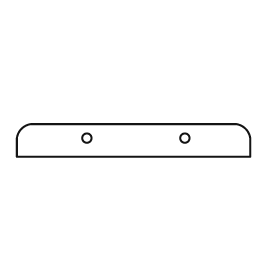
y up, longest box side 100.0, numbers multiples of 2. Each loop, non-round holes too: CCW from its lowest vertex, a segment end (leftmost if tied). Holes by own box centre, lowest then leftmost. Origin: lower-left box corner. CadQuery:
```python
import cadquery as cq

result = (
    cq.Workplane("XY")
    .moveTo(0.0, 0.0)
    .lineTo(100.0, 0.0)
    .lineTo(100.0, 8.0)
    .threePointArc((98.0, 12.0), (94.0, 14.0))
    .lineTo(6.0, 14.0)
    .threePointArc((2.0, 12.0), (0.0, 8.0))
    .close()
    .moveTo(30.0, 8.0)
    .circle(2.0)
    .moveTo(72.0, 8.0)
    .circle(2.0)
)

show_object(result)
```